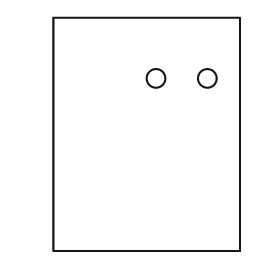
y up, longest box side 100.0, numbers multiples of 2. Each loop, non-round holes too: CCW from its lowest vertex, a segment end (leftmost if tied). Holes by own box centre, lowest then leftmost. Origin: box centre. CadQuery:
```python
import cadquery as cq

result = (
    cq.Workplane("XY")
    .moveTo(-40.0, -50.0)
    .lineTo(40.0, -50.0)
    .lineTo(40.0, 50.0)
    .lineTo(-40.0, 50.0)
    .close()
    .moveTo(4.0, 24.0)
    .circle(4.0)
    .moveTo(26.0, 24.0)
    .circle(4.0)
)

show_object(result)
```